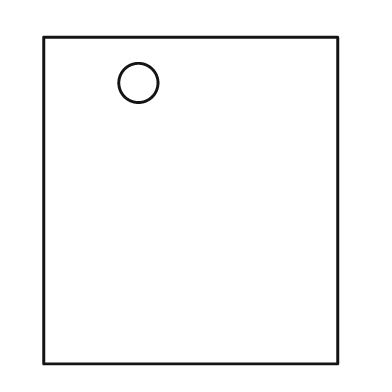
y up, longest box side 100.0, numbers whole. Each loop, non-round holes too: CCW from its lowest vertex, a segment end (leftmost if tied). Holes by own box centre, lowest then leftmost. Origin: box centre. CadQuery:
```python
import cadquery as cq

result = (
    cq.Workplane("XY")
    .moveTo(-45.0, -50.0)
    .lineTo(45.0, -50.0)
    .lineTo(45.0, 50.0)
    .lineTo(-45.0, 50.0)
    .close()
    .moveTo(-16.0, 36.0)
    .circle(6.0)
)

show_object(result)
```